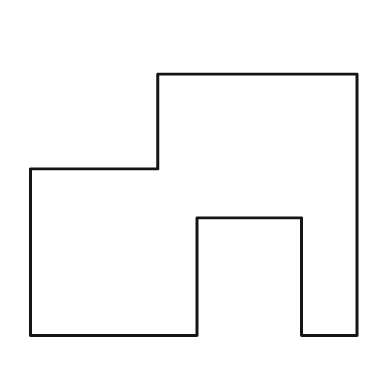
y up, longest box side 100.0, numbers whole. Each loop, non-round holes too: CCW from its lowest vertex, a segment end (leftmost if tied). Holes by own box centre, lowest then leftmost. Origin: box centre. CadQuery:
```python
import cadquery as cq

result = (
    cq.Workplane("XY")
    .moveTo(-50.0, -40.0)
    .lineTo(1.0, -40.0)
    .lineTo(1.0, -4.0)
    .lineTo(33.0, -4.0)
    .lineTo(33.0, -40.0)
    .lineTo(50.0, -40.0)
    .lineTo(50.0, 40.0)
    .lineTo(-11.0, 40.0)
    .lineTo(-11.0, 11.0)
    .lineTo(-50.0, 11.0)
    .close()
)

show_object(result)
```